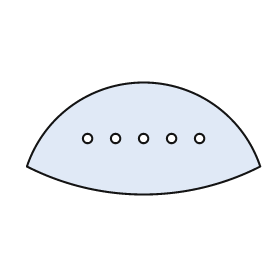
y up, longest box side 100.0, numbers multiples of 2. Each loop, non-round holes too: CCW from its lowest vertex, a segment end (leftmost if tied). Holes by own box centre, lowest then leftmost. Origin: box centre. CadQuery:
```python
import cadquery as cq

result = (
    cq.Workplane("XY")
    .moveTo(-50.0, -12.0)
    .threePointArc((0.0, -24.0), (50.0, -12.0))
    .threePointArc((0.0, 24.0), (-50.0, -12.0))
    .close()
    .moveTo(-24.0, 0.0)
    .circle(2.0)
    .moveTo(-12.0, 0.0)
    .circle(2.0)
    .moveTo(0.0, 0.0)
    .circle(2.0)
    .moveTo(12.0, 0.0)
    .circle(2.0)
    .moveTo(24.0, 0.0)
    .circle(2.0)
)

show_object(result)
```